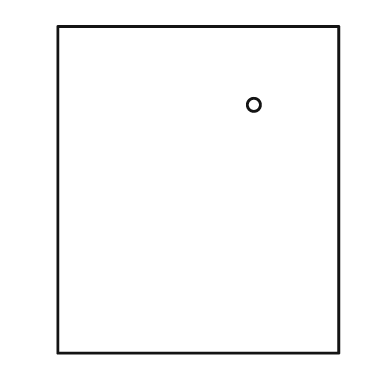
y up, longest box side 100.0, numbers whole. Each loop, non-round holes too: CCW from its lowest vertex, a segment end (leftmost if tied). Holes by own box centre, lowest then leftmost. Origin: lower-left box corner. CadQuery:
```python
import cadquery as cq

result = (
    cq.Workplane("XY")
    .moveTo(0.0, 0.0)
    .lineTo(86.0, 0.0)
    .lineTo(86.0, 100.0)
    .lineTo(0.0, 100.0)
    .close()
    .moveTo(60.0, 76.0)
    .circle(2.0)
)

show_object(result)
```